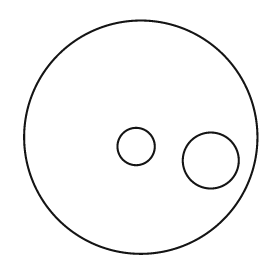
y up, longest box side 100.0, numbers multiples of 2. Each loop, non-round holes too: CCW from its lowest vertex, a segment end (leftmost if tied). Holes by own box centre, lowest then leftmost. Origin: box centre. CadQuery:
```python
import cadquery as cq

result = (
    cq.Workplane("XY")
    .moveTo(0.0, 0.0)
    .circle(50.0)
    .moveTo(30.0, -10.0)
    .circle(12.0)
    .moveTo(-2.0, -4.0)
    .circle(8.0)
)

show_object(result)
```